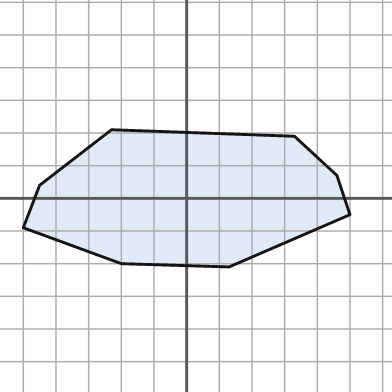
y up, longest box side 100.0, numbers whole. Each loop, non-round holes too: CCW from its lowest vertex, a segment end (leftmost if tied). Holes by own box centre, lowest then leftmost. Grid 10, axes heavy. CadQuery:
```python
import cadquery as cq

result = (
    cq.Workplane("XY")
    .moveTo(13.0, -21.0)
    .lineTo(50.0, -5.0)
    .lineTo(46.0, 7.0)
    .lineTo(33.0, 19.0)
    .lineTo(-23.0, 21.0)
    .lineTo(-45.0, 4.0)
    .lineTo(-50.0, -9.0)
    .lineTo(-20.0, -20.0)
    .close()
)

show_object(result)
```